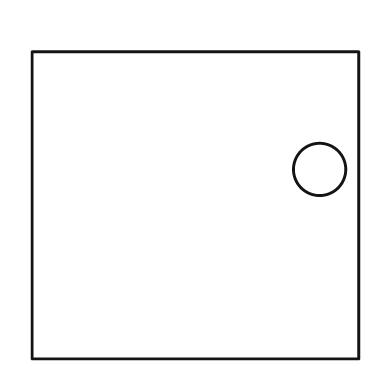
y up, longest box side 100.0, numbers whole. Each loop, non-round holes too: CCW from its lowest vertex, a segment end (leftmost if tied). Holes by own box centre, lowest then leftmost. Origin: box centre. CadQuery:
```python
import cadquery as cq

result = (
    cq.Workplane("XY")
    .moveTo(-50.0, -47.0)
    .lineTo(50.0, -47.0)
    .lineTo(50.0, 47.0)
    .lineTo(-50.0, 47.0)
    .close()
    .moveTo(38.0, 11.0)
    .circle(8.0)
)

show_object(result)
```